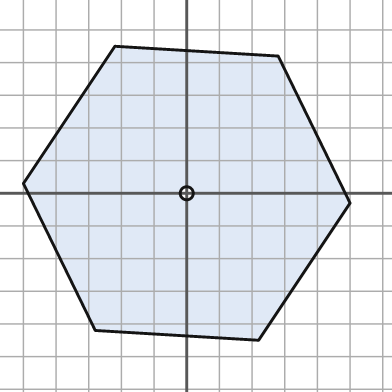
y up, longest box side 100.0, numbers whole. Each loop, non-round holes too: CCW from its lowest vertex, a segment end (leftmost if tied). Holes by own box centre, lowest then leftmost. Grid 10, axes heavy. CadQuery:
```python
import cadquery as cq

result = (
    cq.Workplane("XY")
    .moveTo(22.0, -45.0)
    .lineTo(50.0, -3.0)
    .lineTo(28.0, 42.0)
    .lineTo(-22.0, 45.0)
    .lineTo(-50.0, 3.0)
    .lineTo(-28.0, -42.0)
    .close()
    .moveTo(0.0, 0.0)
    .circle(2.0)
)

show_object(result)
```